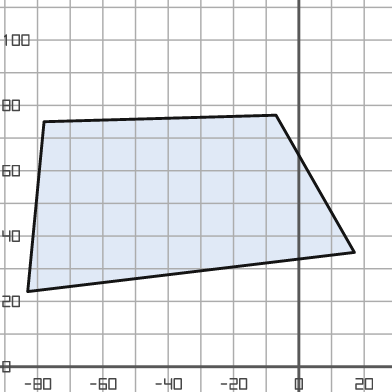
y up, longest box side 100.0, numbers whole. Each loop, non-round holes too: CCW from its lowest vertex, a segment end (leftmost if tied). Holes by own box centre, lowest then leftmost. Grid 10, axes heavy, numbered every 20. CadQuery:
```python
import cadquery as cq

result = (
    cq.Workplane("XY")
    .moveTo(-83.0, 23.0)
    .lineTo(17.0, 35.0)
    .lineTo(-7.0, 77.0)
    .lineTo(-78.0, 75.0)
    .close()
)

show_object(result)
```